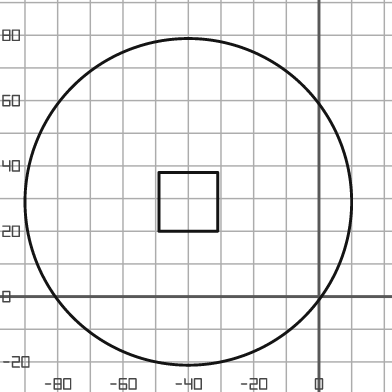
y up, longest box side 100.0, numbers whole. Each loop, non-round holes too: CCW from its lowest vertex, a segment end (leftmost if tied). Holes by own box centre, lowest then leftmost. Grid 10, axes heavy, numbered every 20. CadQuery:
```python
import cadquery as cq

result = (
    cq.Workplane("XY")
    .moveTo(-40.0, 29.0)
    .circle(50.0)
    .moveTo(-49.0, 20.0)
    .lineTo(-31.0, 20.0)
    .lineTo(-31.0, 38.0)
    .lineTo(-49.0, 38.0)
    .close()
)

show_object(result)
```